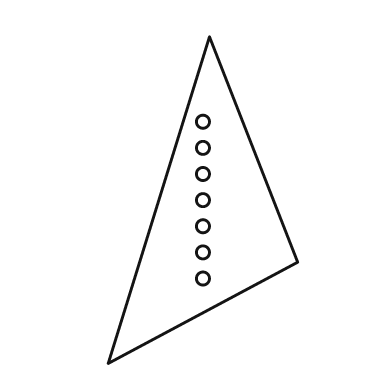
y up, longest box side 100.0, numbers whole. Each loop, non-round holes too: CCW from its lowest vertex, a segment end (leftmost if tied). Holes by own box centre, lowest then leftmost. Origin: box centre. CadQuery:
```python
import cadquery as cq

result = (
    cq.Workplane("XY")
    .moveTo(-29.0, -50.0)
    .lineTo(29.0, -19.0)
    .lineTo(2.0, 50.0)
    .close()
    .moveTo(0.0, -24.0)
    .circle(2.0)
    .moveTo(0.0, -16.0)
    .circle(2.0)
    .moveTo(0.0, -8.0)
    .circle(2.0)
    .moveTo(0.0, 0.0)
    .circle(2.0)
    .moveTo(0.0, 8.0)
    .circle(2.0)
    .moveTo(0.0, 16.0)
    .circle(2.0)
    .moveTo(0.0, 24.0)
    .circle(2.0)
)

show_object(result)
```